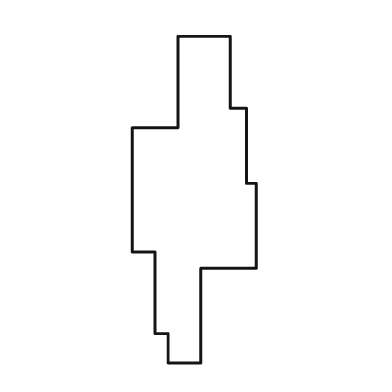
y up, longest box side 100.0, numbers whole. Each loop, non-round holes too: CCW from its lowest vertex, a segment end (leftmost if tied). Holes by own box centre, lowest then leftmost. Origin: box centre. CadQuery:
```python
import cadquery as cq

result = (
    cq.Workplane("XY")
    .moveTo(-8.0, -50.0)
    .lineTo(2.0, -50.0)
    .lineTo(2.0, -21.0)
    .lineTo(19.0, -21.0)
    .lineTo(19.0, 5.0)
    .lineTo(16.0, 5.0)
    .lineTo(16.0, 28.0)
    .lineTo(11.0, 28.0)
    .lineTo(11.0, 50.0)
    .lineTo(-5.0, 50.0)
    .lineTo(-5.0, 22.0)
    .lineTo(-19.0, 22.0)
    .lineTo(-19.0, -16.0)
    .lineTo(-12.0, -16.0)
    .lineTo(-12.0, -41.0)
    .lineTo(-8.0, -41.0)
    .close()
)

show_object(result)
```